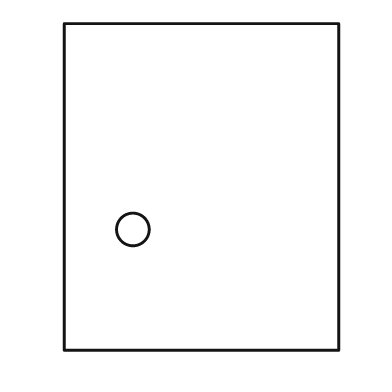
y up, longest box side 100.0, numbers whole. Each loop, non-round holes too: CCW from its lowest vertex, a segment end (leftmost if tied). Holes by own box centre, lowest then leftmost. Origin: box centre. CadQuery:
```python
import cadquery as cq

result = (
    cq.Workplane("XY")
    .moveTo(-42.0, -50.0)
    .lineTo(42.0, -50.0)
    .lineTo(42.0, 50.0)
    .lineTo(-42.0, 50.0)
    .close()
    .moveTo(-21.0, -13.0)
    .circle(5.0)
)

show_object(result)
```